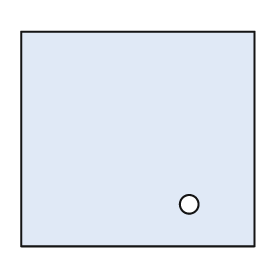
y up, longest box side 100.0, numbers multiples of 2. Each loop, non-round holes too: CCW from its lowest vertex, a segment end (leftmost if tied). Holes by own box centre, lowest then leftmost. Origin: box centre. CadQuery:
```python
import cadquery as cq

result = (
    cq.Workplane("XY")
    .moveTo(-50.0, -46.0)
    .lineTo(50.0, -46.0)
    .lineTo(50.0, 46.0)
    .lineTo(-50.0, 46.0)
    .close()
    .moveTo(22.0, -28.0)
    .circle(4.0)
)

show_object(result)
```